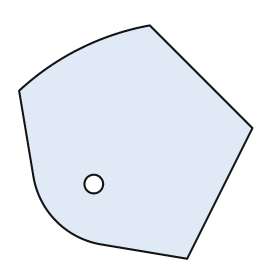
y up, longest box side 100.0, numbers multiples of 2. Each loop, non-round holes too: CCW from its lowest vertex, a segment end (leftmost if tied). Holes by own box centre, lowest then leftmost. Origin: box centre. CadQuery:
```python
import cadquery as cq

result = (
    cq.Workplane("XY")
    .moveTo(22.0, -50.0)
    .lineTo(50.0, 6.0)
    .lineTo(6.0, 50.0)
    .threePointArc((-24.0, 40.0), (-50.0, 22.0))
    .lineTo(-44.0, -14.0)
    .threePointArc((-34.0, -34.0), (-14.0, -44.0))
    .close()
    .moveTo(-18.0, -18.0)
    .circle(4.0)
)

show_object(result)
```